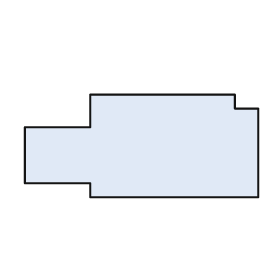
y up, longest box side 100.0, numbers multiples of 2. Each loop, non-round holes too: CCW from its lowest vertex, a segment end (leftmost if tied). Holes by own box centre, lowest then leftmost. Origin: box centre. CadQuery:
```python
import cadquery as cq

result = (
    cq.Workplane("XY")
    .moveTo(-22.0, -22.0)
    .lineTo(50.0, -22.0)
    .lineTo(50.0, 16.0)
    .lineTo(40.0, 16.0)
    .lineTo(40.0, 22.0)
    .lineTo(-22.0, 22.0)
    .lineTo(-22.0, 8.0)
    .lineTo(-50.0, 8.0)
    .lineTo(-50.0, -16.0)
    .lineTo(-22.0, -16.0)
    .close()
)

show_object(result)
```